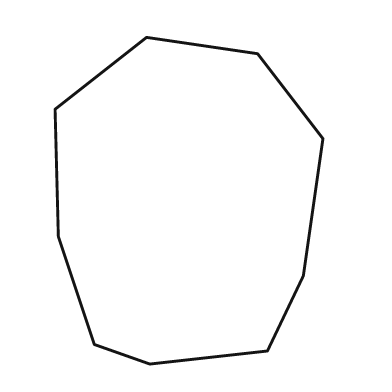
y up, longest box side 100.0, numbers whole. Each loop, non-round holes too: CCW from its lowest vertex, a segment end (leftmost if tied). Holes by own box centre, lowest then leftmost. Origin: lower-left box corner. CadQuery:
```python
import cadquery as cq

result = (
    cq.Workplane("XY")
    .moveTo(29.0, 0.0)
    .lineTo(65.0, 4.0)
    .lineTo(76.0, 27.0)
    .lineTo(82.0, 69.0)
    .lineTo(62.0, 95.0)
    .lineTo(28.0, 100.0)
    .lineTo(0.0, 78.0)
    .lineTo(1.0, 39.0)
    .lineTo(12.0, 6.0)
    .close()
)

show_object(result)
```